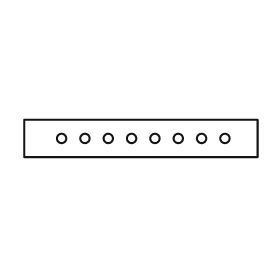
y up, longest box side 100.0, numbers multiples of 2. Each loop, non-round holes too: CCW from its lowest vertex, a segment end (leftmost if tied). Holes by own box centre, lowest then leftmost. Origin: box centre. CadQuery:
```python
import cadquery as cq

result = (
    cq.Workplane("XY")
    .moveTo(-50.0, -8.0)
    .lineTo(50.0, -8.0)
    .lineTo(50.0, 8.0)
    .lineTo(-50.0, 8.0)
    .close()
    .moveTo(-34.0, 0.0)
    .circle(2.0)
    .moveTo(-24.0, 0.0)
    .circle(2.0)
    .moveTo(-14.0, 0.0)
    .circle(2.0)
    .moveTo(-4.0, 0.0)
    .circle(2.0)
    .moveTo(6.0, 0.0)
    .circle(2.0)
    .moveTo(16.0, 0.0)
    .circle(2.0)
    .moveTo(26.0, 0.0)
    .circle(2.0)
    .moveTo(36.0, 0.0)
    .circle(2.0)
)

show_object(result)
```